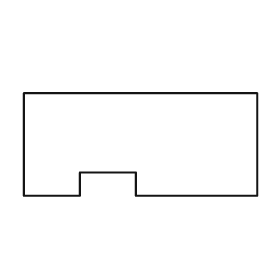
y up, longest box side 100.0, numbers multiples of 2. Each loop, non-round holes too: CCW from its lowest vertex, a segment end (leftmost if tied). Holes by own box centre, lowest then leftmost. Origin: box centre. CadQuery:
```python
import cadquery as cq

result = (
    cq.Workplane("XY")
    .moveTo(-50.0, -22.0)
    .lineTo(-26.0, -22.0)
    .lineTo(-26.0, -12.0)
    .lineTo(-2.0, -12.0)
    .lineTo(-2.0, -22.0)
    .lineTo(50.0, -22.0)
    .lineTo(50.0, 22.0)
    .lineTo(-50.0, 22.0)
    .close()
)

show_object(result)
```